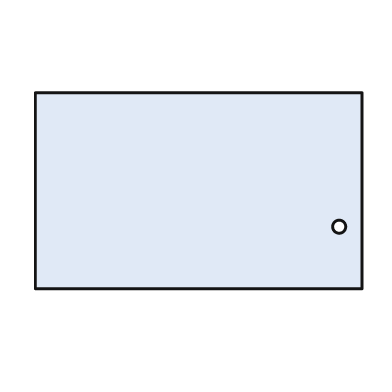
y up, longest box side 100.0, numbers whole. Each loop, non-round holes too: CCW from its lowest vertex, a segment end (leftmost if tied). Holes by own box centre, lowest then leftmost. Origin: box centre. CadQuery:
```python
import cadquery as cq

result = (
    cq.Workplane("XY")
    .moveTo(-50.0, -30.0)
    .lineTo(50.0, -30.0)
    .lineTo(50.0, 30.0)
    .lineTo(-50.0, 30.0)
    .close()
    .moveTo(43.0, -11.0)
    .circle(2.0)
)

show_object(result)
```